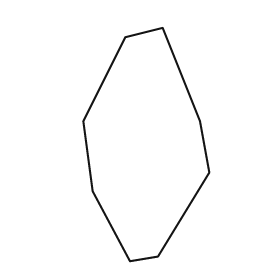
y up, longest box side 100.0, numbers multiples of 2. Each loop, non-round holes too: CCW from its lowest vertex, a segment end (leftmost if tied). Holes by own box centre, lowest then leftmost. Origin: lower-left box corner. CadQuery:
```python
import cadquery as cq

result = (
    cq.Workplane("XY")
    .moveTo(20.0, 0.0)
    .lineTo(32.0, 2.0)
    .lineTo(54.0, 38.0)
    .lineTo(50.0, 60.0)
    .lineTo(34.0, 100.0)
    .lineTo(18.0, 96.0)
    .lineTo(0.0, 60.0)
    .lineTo(4.0, 30.0)
    .close()
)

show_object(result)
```